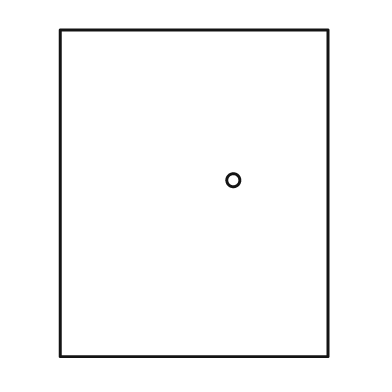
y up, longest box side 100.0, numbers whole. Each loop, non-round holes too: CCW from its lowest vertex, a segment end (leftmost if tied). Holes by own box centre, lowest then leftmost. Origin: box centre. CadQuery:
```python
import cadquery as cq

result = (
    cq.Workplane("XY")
    .moveTo(-41.0, -50.0)
    .lineTo(41.0, -50.0)
    .lineTo(41.0, 50.0)
    .lineTo(-41.0, 50.0)
    .close()
    .moveTo(12.0, 4.0)
    .circle(2.0)
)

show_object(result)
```